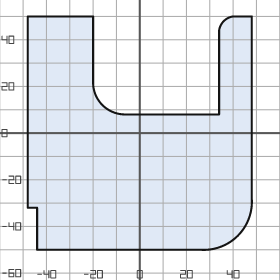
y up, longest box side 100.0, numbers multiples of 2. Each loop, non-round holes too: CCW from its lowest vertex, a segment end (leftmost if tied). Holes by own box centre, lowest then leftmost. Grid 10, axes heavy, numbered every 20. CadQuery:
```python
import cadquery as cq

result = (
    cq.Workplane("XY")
    .moveTo(-44.0, -50.0)
    .lineTo(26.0, -50.0)
    .threePointArc((42.0, -44.0), (48.0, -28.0))
    .lineTo(48.0, 50.0)
    .lineTo(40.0, 50.0)
    .threePointArc((36.0, 48.0), (34.0, 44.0))
    .lineTo(34.0, 8.0)
    .lineTo(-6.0, 8.0)
    .threePointArc((-16.0, 12.0), (-20.0, 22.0))
    .lineTo(-20.0, 50.0)
    .lineTo(-48.0, 50.0)
    .lineTo(-48.0, -32.0)
    .lineTo(-44.0, -32.0)
    .close()
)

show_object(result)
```